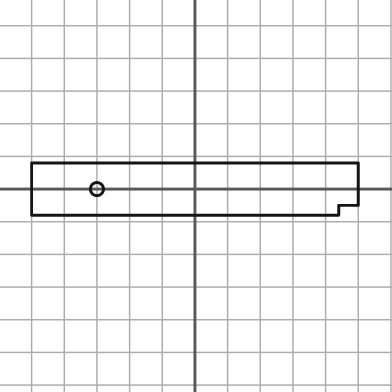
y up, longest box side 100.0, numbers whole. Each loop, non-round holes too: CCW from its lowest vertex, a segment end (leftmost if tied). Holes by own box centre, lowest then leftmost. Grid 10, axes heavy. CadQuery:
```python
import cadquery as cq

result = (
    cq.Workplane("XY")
    .moveTo(-50.0, -8.0)
    .lineTo(44.0, -8.0)
    .lineTo(44.0, -5.0)
    .lineTo(50.0, -5.0)
    .lineTo(50.0, 8.0)
    .lineTo(-50.0, 8.0)
    .close()
    .moveTo(-30.0, 0.0)
    .circle(2.0)
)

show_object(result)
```